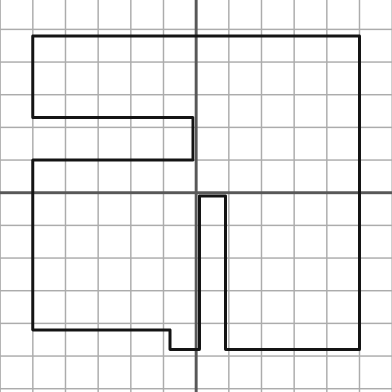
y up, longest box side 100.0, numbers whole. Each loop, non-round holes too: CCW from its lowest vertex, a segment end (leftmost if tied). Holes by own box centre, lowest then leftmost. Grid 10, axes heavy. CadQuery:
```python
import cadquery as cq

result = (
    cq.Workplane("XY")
    .moveTo(-8.0, -48.0)
    .lineTo(1.0, -48.0)
    .lineTo(1.0, -1.0)
    .lineTo(9.0, -1.0)
    .lineTo(9.0, -48.0)
    .lineTo(50.0, -48.0)
    .lineTo(50.0, 48.0)
    .lineTo(-50.0, 48.0)
    .lineTo(-50.0, 23.0)
    .lineTo(-1.0, 23.0)
    .lineTo(-1.0, 10.0)
    .lineTo(-50.0, 10.0)
    .lineTo(-50.0, -42.0)
    .lineTo(-8.0, -42.0)
    .close()
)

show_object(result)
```